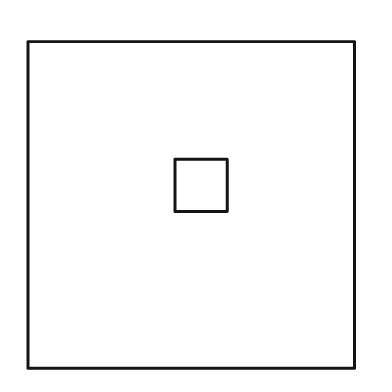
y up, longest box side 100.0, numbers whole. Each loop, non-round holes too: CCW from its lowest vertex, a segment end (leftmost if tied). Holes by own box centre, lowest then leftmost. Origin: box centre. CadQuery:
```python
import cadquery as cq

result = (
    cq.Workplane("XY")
    .moveTo(-50.0, -50.0)
    .lineTo(50.0, -50.0)
    .lineTo(50.0, 50.0)
    .lineTo(-50.0, 50.0)
    .close()
    .moveTo(-5.0, -2.0)
    .lineTo(11.0, -2.0)
    .lineTo(11.0, 14.0)
    .lineTo(-5.0, 14.0)
    .close()
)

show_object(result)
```